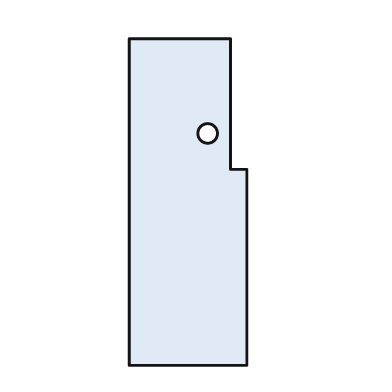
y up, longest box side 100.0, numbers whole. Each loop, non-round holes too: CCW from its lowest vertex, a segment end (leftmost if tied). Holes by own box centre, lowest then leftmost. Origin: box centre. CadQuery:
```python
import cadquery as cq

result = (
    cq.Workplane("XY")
    .moveTo(-18.0, -50.0)
    .lineTo(18.0, -50.0)
    .lineTo(18.0, 10.0)
    .lineTo(13.0, 10.0)
    .lineTo(13.0, 50.0)
    .lineTo(-18.0, 50.0)
    .close()
    .moveTo(6.0, 21.0)
    .circle(3.0)
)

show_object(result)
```